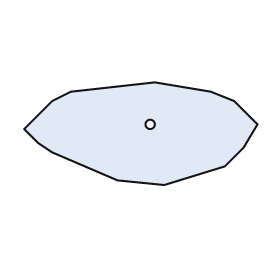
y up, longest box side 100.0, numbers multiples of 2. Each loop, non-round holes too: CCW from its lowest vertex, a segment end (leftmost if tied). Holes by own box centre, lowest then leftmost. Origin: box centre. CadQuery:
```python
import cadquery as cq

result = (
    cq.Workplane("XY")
    .moveTo(10.0, -22.0)
    .lineTo(36.0, -14.0)
    .lineTo(44.0, -6.0)
    .lineTo(50.0, 4.0)
    .lineTo(40.0, 14.0)
    .lineTo(30.0, 18.0)
    .lineTo(6.0, 22.0)
    .lineTo(-30.0, 18.0)
    .lineTo(-38.0, 14.0)
    .lineTo(-50.0, 2.0)
    .lineTo(-44.0, -4.0)
    .lineTo(-38.0, -8.0)
    .lineTo(-10.0, -20.0)
    .close()
    .moveTo(4.0, 4.0)
    .circle(2.0)
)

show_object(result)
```